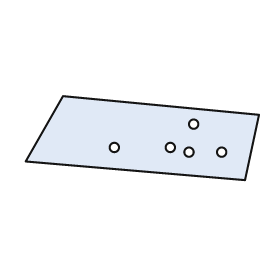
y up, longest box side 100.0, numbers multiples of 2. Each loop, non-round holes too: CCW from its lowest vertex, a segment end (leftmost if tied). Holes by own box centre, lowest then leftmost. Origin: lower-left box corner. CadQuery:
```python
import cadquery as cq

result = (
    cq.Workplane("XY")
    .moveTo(94.0, 0.0)
    .lineTo(100.0, 28.0)
    .lineTo(16.0, 36.0)
    .lineTo(0.0, 8.0)
    .close()
    .moveTo(70.0, 12.0)
    .circle(2.0)
    .moveTo(84.0, 12.0)
    .circle(2.0)
    .moveTo(38.0, 14.0)
    .circle(2.0)
    .moveTo(62.0, 14.0)
    .circle(2.0)
    .moveTo(72.0, 24.0)
    .circle(2.0)
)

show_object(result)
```